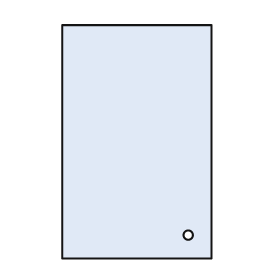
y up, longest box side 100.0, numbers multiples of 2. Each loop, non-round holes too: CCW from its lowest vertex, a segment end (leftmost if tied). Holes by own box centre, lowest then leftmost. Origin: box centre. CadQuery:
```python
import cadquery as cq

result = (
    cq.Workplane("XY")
    .moveTo(-32.0, -50.0)
    .lineTo(32.0, -50.0)
    .lineTo(32.0, 50.0)
    .lineTo(-32.0, 50.0)
    .close()
    .moveTo(22.0, -40.0)
    .circle(2.0)
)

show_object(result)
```